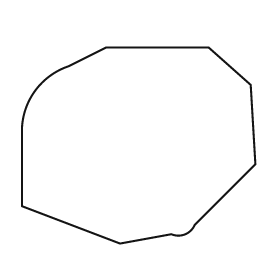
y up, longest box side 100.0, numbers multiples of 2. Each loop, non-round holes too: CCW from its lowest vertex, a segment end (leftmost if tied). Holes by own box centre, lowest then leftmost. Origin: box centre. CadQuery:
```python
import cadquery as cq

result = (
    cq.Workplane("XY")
    .moveTo(-8.0, -42.0)
    .lineTo(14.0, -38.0)
    .threePointArc((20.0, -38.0), (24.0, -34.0))
    .lineTo(50.0, -8.0)
    .lineTo(48.0, 26.0)
    .lineTo(30.0, 42.0)
    .lineTo(-14.0, 42.0)
    .lineTo(-30.0, 34.0)
    .threePointArc((-44.0, 24.0), (-50.0, 8.0))
    .lineTo(-50.0, -26.0)
    .close()
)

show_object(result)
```